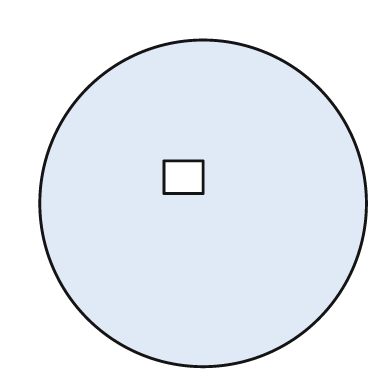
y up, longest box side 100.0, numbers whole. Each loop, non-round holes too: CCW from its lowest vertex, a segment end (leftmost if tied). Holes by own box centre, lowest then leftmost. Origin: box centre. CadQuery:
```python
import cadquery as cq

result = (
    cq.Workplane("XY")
    .moveTo(0.0, 0.0)
    .circle(50.0)
    .moveTo(-12.0, 3.0)
    .lineTo(0.0, 3.0)
    .lineTo(0.0, 13.0)
    .lineTo(-12.0, 13.0)
    .close()
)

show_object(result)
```